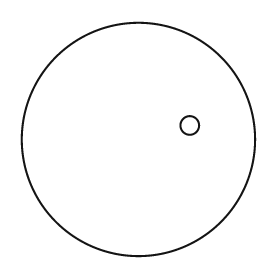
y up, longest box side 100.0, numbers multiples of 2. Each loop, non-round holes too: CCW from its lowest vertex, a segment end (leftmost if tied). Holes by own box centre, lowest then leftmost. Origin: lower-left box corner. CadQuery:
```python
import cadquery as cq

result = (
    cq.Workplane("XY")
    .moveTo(50.0, 50.0)
    .circle(50.0)
    .moveTo(72.0, 56.0)
    .circle(4.0)
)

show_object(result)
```